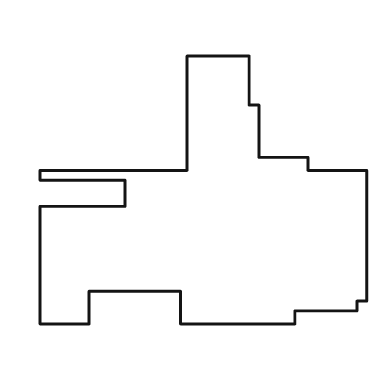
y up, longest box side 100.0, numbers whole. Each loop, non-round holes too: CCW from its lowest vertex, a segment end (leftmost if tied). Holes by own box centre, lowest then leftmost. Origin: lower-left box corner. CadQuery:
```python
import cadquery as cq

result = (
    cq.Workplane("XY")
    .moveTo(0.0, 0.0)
    .lineTo(15.0, 0.0)
    .lineTo(15.0, 10.0)
    .lineTo(43.0, 10.0)
    .lineTo(43.0, 0.0)
    .lineTo(78.0, 0.0)
    .lineTo(78.0, 4.0)
    .lineTo(97.0, 4.0)
    .lineTo(97.0, 7.0)
    .lineTo(100.0, 7.0)
    .lineTo(100.0, 47.0)
    .lineTo(82.0, 47.0)
    .lineTo(82.0, 51.0)
    .lineTo(67.0, 51.0)
    .lineTo(67.0, 67.0)
    .lineTo(64.0, 67.0)
    .lineTo(64.0, 82.0)
    .lineTo(45.0, 82.0)
    .lineTo(45.0, 47.0)
    .lineTo(0.0, 47.0)
    .lineTo(0.0, 44.0)
    .lineTo(26.0, 44.0)
    .lineTo(26.0, 36.0)
    .lineTo(0.0, 36.0)
    .close()
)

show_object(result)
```